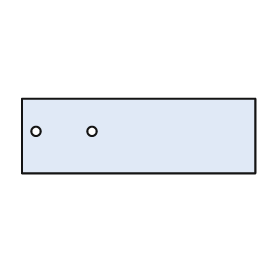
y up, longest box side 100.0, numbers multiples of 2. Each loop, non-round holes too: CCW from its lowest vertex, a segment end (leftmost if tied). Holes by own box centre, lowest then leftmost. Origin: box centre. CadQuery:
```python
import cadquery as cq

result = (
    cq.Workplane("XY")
    .moveTo(-50.0, -16.0)
    .lineTo(50.0, -16.0)
    .lineTo(50.0, 16.0)
    .lineTo(-50.0, 16.0)
    .close()
    .moveTo(-44.0, 2.0)
    .circle(2.0)
    .moveTo(-20.0, 2.0)
    .circle(2.0)
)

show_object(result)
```